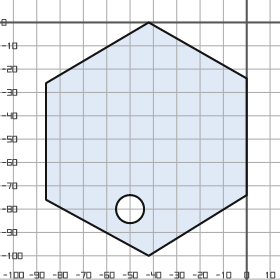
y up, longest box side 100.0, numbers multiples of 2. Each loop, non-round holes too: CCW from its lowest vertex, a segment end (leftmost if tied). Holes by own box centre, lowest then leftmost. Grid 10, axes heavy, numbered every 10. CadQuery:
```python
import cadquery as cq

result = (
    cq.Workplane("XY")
    .moveTo(-42.0, -100.0)
    .lineTo(0.0, -74.0)
    .lineTo(0.0, -24.0)
    .lineTo(-42.0, 0.0)
    .lineTo(-86.0, -26.0)
    .lineTo(-86.0, -76.0)
    .close()
    .moveTo(-50.0, -80.0)
    .circle(6.0)
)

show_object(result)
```